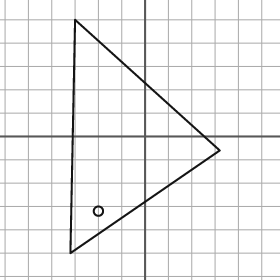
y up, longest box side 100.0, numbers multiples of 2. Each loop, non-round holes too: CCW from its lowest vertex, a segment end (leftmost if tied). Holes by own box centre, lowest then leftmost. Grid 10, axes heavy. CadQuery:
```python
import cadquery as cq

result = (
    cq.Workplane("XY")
    .moveTo(-32.0, -50.0)
    .lineTo(32.0, -6.0)
    .lineTo(-30.0, 50.0)
    .close()
    .moveTo(-20.0, -32.0)
    .circle(2.0)
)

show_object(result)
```